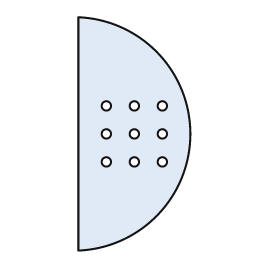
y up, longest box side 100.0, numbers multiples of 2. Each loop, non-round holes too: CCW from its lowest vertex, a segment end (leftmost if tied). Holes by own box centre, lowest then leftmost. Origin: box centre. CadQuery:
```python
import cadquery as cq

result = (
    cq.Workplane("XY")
    .moveTo(-24.0, -50.0)
    .threePointArc((24.0, 0.0), (-24.0, 50.0))
    .close()
    .moveTo(-12.0, -12.0)
    .circle(2.0)
    .moveTo(0.0, -12.0)
    .circle(2.0)
    .moveTo(12.0, -12.0)
    .circle(2.0)
    .moveTo(-12.0, 0.0)
    .circle(2.0)
    .moveTo(0.0, 0.0)
    .circle(2.0)
    .moveTo(12.0, 0.0)
    .circle(2.0)
    .moveTo(-12.0, 12.0)
    .circle(2.0)
    .moveTo(0.0, 12.0)
    .circle(2.0)
    .moveTo(12.0, 12.0)
    .circle(2.0)
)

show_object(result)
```